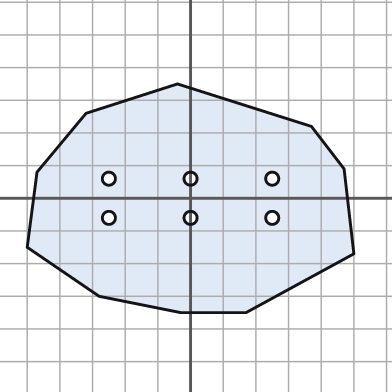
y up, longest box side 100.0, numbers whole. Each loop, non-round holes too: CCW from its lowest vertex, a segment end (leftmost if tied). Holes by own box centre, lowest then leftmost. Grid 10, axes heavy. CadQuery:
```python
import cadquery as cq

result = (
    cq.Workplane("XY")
    .moveTo(-3.0, -35.0)
    .lineTo(17.0, -35.0)
    .lineTo(50.0, -17.0)
    .lineTo(47.0, 9.0)
    .lineTo(37.0, 22.0)
    .lineTo(-4.0, 35.0)
    .lineTo(-32.0, 26.0)
    .lineTo(-47.0, 8.0)
    .lineTo(-50.0, -15.0)
    .lineTo(-28.0, -30.0)
    .close()
    .moveTo(-25.0, -6.0)
    .circle(2.0)
    .moveTo(0.0, -6.0)
    .circle(2.0)
    .moveTo(25.0, -6.0)
    .circle(2.0)
    .moveTo(-25.0, 6.0)
    .circle(2.0)
    .moveTo(0.0, 6.0)
    .circle(2.0)
    .moveTo(25.0, 6.0)
    .circle(2.0)
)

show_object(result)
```